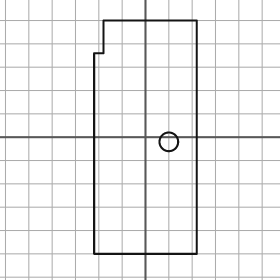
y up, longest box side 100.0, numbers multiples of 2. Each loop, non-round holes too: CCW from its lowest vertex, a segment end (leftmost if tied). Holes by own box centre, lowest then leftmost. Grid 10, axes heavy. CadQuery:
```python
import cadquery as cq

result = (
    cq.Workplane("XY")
    .moveTo(-22.0, -50.0)
    .lineTo(22.0, -50.0)
    .lineTo(22.0, 50.0)
    .lineTo(-18.0, 50.0)
    .lineTo(-18.0, 36.0)
    .lineTo(-22.0, 36.0)
    .close()
    .moveTo(10.0, -2.0)
    .circle(4.0)
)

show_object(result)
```